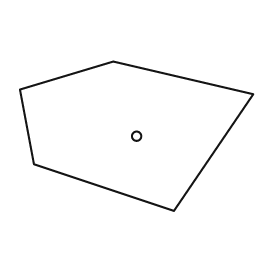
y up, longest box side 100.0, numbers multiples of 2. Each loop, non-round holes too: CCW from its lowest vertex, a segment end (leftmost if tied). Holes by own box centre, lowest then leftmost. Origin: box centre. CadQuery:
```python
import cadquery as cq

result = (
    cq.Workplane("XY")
    .moveTo(16.0, -32.0)
    .lineTo(50.0, 18.0)
    .lineTo(-10.0, 32.0)
    .lineTo(-50.0, 20.0)
    .lineTo(-44.0, -12.0)
    .close()
    .moveTo(0.0, 0.0)
    .circle(2.0)
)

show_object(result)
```